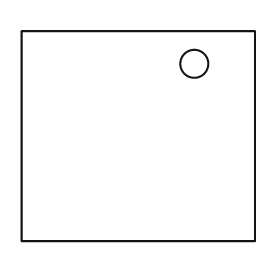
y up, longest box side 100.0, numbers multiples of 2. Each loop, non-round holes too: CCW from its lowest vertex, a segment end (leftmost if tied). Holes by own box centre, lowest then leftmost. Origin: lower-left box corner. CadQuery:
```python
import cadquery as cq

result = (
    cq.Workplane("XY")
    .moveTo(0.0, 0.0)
    .lineTo(100.0, 0.0)
    .lineTo(100.0, 90.0)
    .lineTo(0.0, 90.0)
    .close()
    .moveTo(74.0, 76.0)
    .circle(6.0)
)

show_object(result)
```